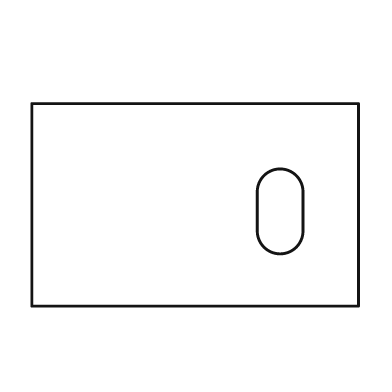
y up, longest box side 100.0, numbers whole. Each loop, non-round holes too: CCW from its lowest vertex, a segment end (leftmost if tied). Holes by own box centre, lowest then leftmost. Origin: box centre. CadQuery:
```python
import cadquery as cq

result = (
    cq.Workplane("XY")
    .moveTo(-50.0, -31.0)
    .lineTo(50.0, -31.0)
    .lineTo(50.0, 31.0)
    .lineTo(-50.0, 31.0)
    .close()
    .moveTo(19.0, -8.0)
    .threePointArc((26.0, -15.0), (33.0, -8.0))
    .lineTo(33.0, 4.0)
    .threePointArc((26.0, 11.0), (19.0, 4.0))
    .close()
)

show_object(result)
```